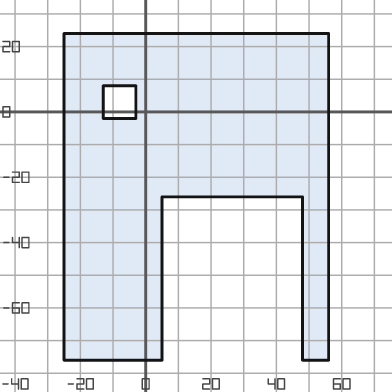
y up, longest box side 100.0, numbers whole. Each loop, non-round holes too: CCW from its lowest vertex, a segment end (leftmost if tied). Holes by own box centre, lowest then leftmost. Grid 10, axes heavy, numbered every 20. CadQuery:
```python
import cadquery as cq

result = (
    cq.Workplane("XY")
    .moveTo(-25.0, -76.0)
    .lineTo(5.0, -76.0)
    .lineTo(5.0, -26.0)
    .lineTo(48.0, -26.0)
    .lineTo(48.0, -76.0)
    .lineTo(56.0, -76.0)
    .lineTo(56.0, 24.0)
    .lineTo(-25.0, 24.0)
    .close()
    .moveTo(-13.0, -2.0)
    .lineTo(-3.0, -2.0)
    .lineTo(-3.0, 8.0)
    .lineTo(-13.0, 8.0)
    .close()
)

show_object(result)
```